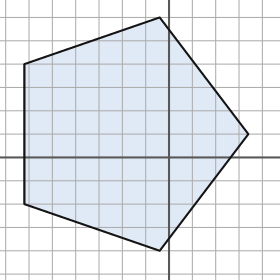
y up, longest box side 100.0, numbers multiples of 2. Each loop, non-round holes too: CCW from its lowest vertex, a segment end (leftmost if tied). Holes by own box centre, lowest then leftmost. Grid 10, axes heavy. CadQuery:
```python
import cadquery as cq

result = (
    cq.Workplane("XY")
    .moveTo(-4.0, -40.0)
    .lineTo(34.0, 10.0)
    .lineTo(-4.0, 60.0)
    .lineTo(-62.0, 40.0)
    .lineTo(-62.0, -20.0)
    .close()
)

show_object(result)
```